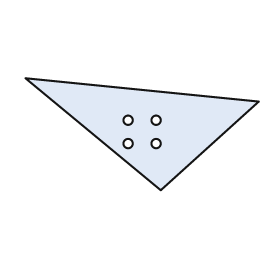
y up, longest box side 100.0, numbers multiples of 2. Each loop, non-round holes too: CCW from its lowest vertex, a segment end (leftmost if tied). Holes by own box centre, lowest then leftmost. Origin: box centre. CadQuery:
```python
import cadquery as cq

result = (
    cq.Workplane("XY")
    .moveTo(8.0, -24.0)
    .lineTo(50.0, 14.0)
    .lineTo(-50.0, 24.0)
    .close()
    .moveTo(-6.0, -4.0)
    .circle(2.0)
    .moveTo(6.0, -4.0)
    .circle(2.0)
    .moveTo(-6.0, 6.0)
    .circle(2.0)
    .moveTo(6.0, 6.0)
    .circle(2.0)
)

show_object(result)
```